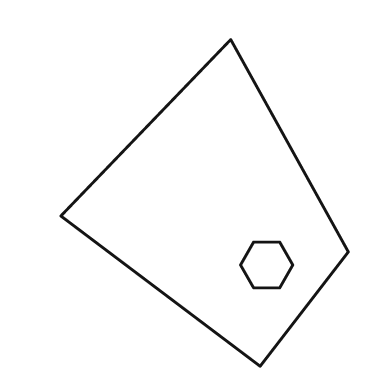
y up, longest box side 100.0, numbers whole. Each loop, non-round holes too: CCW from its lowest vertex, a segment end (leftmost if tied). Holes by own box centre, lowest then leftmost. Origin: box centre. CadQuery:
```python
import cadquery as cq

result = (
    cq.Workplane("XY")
    .moveTo(17.0, -50.0)
    .lineTo(44.0, -15.0)
    .lineTo(8.0, 50.0)
    .lineTo(-44.0, -4.0)
    .close()
    .moveTo(15.0, -26.0)
    .lineTo(23.0, -26.0)
    .lineTo(27.0, -19.0)
    .lineTo(23.0, -12.0)
    .lineTo(15.0, -12.0)
    .lineTo(11.0, -19.0)
    .close()
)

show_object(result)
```